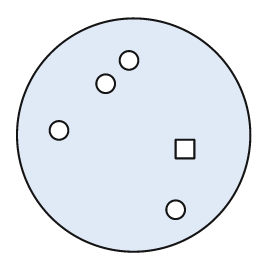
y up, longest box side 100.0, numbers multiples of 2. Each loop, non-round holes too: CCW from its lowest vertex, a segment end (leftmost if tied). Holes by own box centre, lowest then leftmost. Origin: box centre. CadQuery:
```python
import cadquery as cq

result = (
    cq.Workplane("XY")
    .moveTo(0.0, 0.0)
    .circle(50.0)
    .moveTo(18.0, -32.0)
    .circle(4.0)
    .moveTo(18.0, -10.0)
    .lineTo(26.0, -10.0)
    .lineTo(26.0, -2.0)
    .lineTo(18.0, -2.0)
    .close()
    .moveTo(-32.0, 2.0)
    .circle(4.0)
    .moveTo(-12.0, 22.0)
    .circle(4.0)
    .moveTo(-2.0, 32.0)
    .circle(4.0)
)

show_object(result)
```